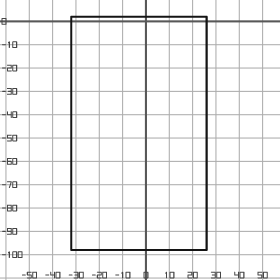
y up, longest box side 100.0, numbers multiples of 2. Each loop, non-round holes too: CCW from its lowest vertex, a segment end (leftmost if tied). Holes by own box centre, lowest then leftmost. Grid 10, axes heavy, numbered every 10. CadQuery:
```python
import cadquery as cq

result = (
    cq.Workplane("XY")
    .moveTo(-32.0, -98.0)
    .lineTo(26.0, -98.0)
    .lineTo(26.0, 2.0)
    .lineTo(-32.0, 2.0)
    .close()
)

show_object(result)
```